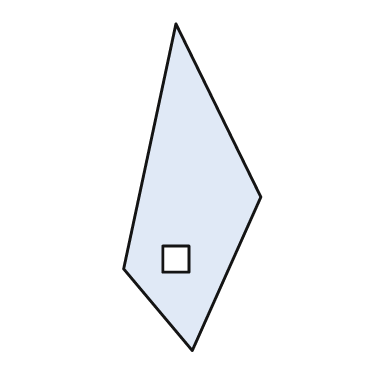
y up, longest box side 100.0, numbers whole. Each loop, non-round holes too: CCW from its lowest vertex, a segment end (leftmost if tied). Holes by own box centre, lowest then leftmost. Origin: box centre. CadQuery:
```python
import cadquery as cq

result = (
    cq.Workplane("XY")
    .moveTo(0.0, -50.0)
    .lineTo(21.0, -3.0)
    .lineTo(-5.0, 50.0)
    .lineTo(-21.0, -25.0)
    .close()
    .moveTo(-9.0, -26.0)
    .lineTo(-1.0, -26.0)
    .lineTo(-1.0, -18.0)
    .lineTo(-9.0, -18.0)
    .close()
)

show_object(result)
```